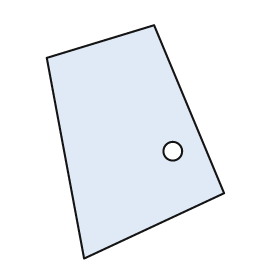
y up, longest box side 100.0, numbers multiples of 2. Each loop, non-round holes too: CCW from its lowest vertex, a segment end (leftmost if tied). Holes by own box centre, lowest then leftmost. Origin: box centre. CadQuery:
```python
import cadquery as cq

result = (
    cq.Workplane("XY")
    .moveTo(-22.0, -50.0)
    .lineTo(38.0, -22.0)
    .lineTo(8.0, 50.0)
    .lineTo(-38.0, 36.0)
    .close()
    .moveTo(16.0, -4.0)
    .circle(4.0)
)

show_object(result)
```